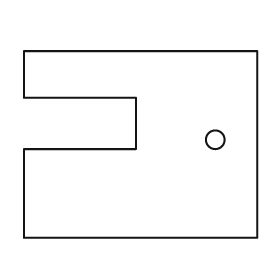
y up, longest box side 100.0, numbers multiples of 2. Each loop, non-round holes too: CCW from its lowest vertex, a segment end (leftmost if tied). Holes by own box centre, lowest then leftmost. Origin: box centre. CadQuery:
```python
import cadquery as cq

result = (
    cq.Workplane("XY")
    .moveTo(-50.0, -40.0)
    .lineTo(50.0, -40.0)
    .lineTo(50.0, 40.0)
    .lineTo(-50.0, 40.0)
    .lineTo(-50.0, 20.0)
    .lineTo(-2.0, 20.0)
    .lineTo(-2.0, -2.0)
    .lineTo(-50.0, -2.0)
    .close()
    .moveTo(32.0, 2.0)
    .circle(4.0)
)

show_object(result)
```